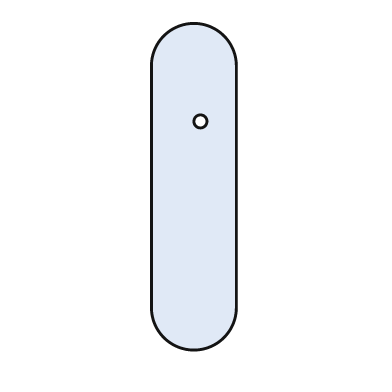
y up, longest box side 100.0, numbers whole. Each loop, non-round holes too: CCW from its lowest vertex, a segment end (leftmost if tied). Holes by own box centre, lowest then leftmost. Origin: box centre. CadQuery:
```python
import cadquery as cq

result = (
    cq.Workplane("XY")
    .moveTo(-13.0, -37.0)
    .threePointArc((0.0, -50.0), (13.0, -37.0))
    .lineTo(13.0, 37.0)
    .threePointArc((0.0, 50.0), (-13.0, 37.0))
    .close()
    .moveTo(2.0, 20.0)
    .circle(2.0)
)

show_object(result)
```